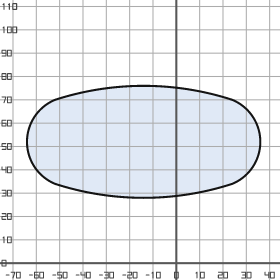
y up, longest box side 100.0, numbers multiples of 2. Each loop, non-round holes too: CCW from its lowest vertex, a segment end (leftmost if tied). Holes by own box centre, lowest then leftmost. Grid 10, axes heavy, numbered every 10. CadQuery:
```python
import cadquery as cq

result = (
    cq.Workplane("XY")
    .moveTo(-52.0, 34.0)
    .threePointArc((-14.0, 28.0), (24.0, 34.0))
    .threePointArc((36.0, 52.0), (24.0, 70.0))
    .threePointArc((-14.0, 76.0), (-52.0, 70.0))
    .threePointArc((-64.0, 52.0), (-52.0, 34.0))
    .close()
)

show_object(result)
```